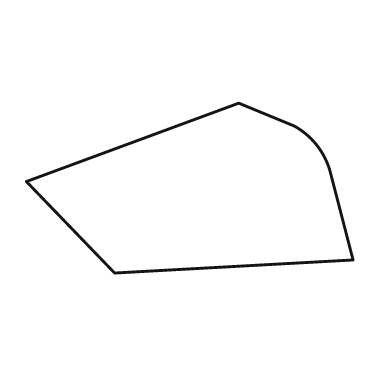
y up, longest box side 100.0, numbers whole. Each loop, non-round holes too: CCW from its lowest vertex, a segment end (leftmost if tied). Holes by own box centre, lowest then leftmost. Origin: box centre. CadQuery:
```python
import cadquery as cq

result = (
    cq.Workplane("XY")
    .moveTo(-23.0, -26.0)
    .lineTo(50.0, -22.0)
    .lineTo(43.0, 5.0)
    .threePointArc((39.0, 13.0), (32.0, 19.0))
    .lineTo(15.0, 26.0)
    .lineTo(-50.0, 2.0)
    .close()
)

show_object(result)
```